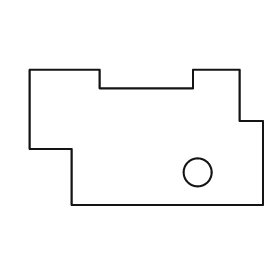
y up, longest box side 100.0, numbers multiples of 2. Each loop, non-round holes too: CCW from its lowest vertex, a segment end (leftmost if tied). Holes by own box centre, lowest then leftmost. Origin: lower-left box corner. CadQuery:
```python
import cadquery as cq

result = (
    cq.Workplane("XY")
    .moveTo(18.0, 0.0)
    .lineTo(100.0, 0.0)
    .lineTo(100.0, 36.0)
    .lineTo(90.0, 36.0)
    .lineTo(90.0, 58.0)
    .lineTo(70.0, 58.0)
    .lineTo(70.0, 50.0)
    .lineTo(30.0, 50.0)
    .lineTo(30.0, 58.0)
    .lineTo(0.0, 58.0)
    .lineTo(0.0, 24.0)
    .lineTo(18.0, 24.0)
    .close()
    .moveTo(72.0, 14.0)
    .circle(6.0)
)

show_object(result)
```